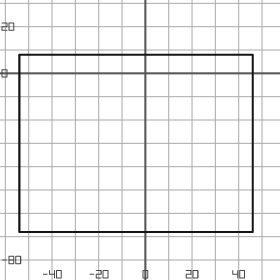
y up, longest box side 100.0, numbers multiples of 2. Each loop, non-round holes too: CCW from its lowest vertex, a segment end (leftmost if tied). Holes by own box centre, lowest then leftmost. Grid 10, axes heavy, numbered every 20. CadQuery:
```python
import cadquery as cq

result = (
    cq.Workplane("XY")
    .moveTo(-54.0, -68.0)
    .lineTo(46.0, -68.0)
    .lineTo(46.0, 8.0)
    .lineTo(-54.0, 8.0)
    .close()
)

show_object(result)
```